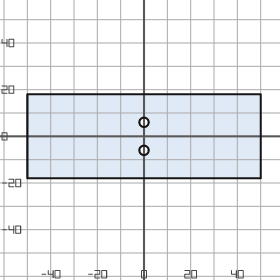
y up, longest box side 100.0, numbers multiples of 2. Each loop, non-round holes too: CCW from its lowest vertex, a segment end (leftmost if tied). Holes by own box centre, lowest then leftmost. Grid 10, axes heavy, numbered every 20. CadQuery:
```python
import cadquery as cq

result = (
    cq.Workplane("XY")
    .moveTo(-50.0, -18.0)
    .lineTo(50.0, -18.0)
    .lineTo(50.0, 18.0)
    .lineTo(-50.0, 18.0)
    .close()
    .moveTo(0.0, -6.0)
    .circle(2.0)
    .moveTo(0.0, 6.0)
    .circle(2.0)
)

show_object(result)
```